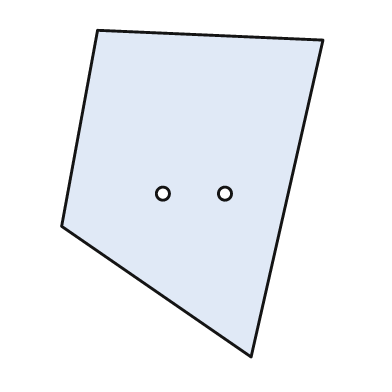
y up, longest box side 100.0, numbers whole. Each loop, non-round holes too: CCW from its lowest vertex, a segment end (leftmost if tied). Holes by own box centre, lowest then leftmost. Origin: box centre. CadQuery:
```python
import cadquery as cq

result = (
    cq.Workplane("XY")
    .moveTo(18.0, -50.0)
    .lineTo(40.0, 47.0)
    .lineTo(-29.0, 50.0)
    .lineTo(-40.0, -10.0)
    .close()
    .moveTo(-9.0, 0.0)
    .circle(2.0)
    .moveTo(10.0, 0.0)
    .circle(2.0)
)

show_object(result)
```